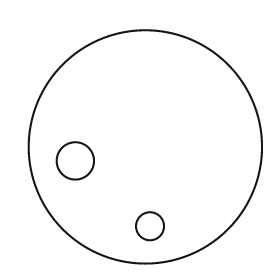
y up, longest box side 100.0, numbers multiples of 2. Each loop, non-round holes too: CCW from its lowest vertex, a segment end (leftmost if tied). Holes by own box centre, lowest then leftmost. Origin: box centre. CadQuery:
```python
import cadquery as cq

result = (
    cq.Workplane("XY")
    .moveTo(0.0, 0.0)
    .circle(50.0)
    .moveTo(2.0, -34.0)
    .circle(6.0)
    .moveTo(-30.0, -6.0)
    .circle(8.0)
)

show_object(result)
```